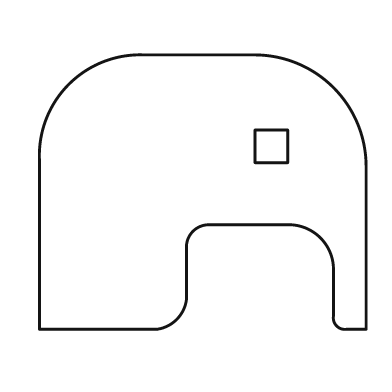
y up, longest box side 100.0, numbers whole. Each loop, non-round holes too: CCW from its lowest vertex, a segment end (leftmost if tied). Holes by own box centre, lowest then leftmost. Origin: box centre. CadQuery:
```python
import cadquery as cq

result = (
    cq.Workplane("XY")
    .moveTo(-50.0, -42.0)
    .lineTo(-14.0, -42.0)
    .threePointArc((-8.0, -39.0), (-5.0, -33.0))
    .lineTo(-5.0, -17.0)
    .threePointArc((-3.0, -12.0), (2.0, -10.0))
    .lineTo(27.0, -10.0)
    .threePointArc((36.0, -14.0), (40.0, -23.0))
    .lineTo(40.0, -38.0)
    .threePointArc((41.0, -41.0), (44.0, -42.0))
    .lineTo(50.0, -42.0)
    .lineTo(50.0, 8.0)
    .threePointArc((40.0, 32.0), (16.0, 42.0))
    .lineTo(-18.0, 42.0)
    .threePointArc((-41.0, 33.0), (-50.0, 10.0))
    .close()
    .moveTo(16.0, 9.0)
    .lineTo(26.0, 9.0)
    .lineTo(26.0, 19.0)
    .lineTo(16.0, 19.0)
    .close()
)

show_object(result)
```